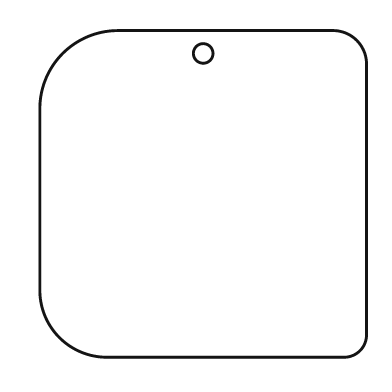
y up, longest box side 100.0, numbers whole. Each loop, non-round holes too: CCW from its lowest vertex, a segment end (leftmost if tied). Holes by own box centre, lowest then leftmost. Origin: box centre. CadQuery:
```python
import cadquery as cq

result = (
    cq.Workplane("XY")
    .moveTo(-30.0, -50.0)
    .lineTo(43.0, -50.0)
    .threePointArc((48.0, -48.0), (50.0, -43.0))
    .lineTo(50.0, 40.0)
    .threePointArc((47.0, 47.0), (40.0, 50.0))
    .lineTo(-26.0, 50.0)
    .threePointArc((-43.0, 43.0), (-50.0, 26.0))
    .lineTo(-50.0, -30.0)
    .threePointArc((-44.0, -44.0), (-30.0, -50.0))
    .close()
    .moveTo(0.0, 43.0)
    .circle(3.0)
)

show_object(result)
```